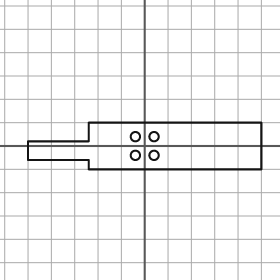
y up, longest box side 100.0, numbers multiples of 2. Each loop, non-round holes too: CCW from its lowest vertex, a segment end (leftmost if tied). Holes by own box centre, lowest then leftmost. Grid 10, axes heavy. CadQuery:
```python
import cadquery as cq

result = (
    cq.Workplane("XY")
    .moveTo(-24.0, -10.0)
    .lineTo(50.0, -10.0)
    .lineTo(50.0, 10.0)
    .lineTo(-24.0, 10.0)
    .lineTo(-24.0, 2.0)
    .lineTo(-50.0, 2.0)
    .lineTo(-50.0, -6.0)
    .lineTo(-24.0, -6.0)
    .close()
    .moveTo(-4.0, -4.0)
    .circle(2.0)
    .moveTo(4.0, -4.0)
    .circle(2.0)
    .moveTo(-4.0, 4.0)
    .circle(2.0)
    .moveTo(4.0, 4.0)
    .circle(2.0)
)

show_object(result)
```